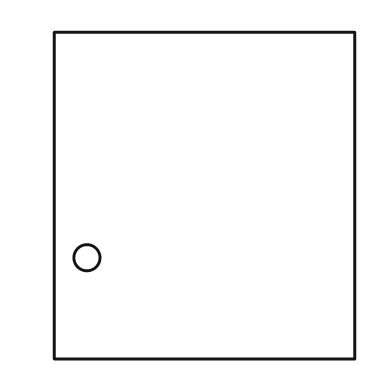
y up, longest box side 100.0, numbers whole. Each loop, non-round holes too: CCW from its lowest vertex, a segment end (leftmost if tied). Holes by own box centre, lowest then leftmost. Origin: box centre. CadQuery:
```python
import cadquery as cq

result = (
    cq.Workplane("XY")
    .moveTo(-46.0, -50.0)
    .lineTo(46.0, -50.0)
    .lineTo(46.0, 50.0)
    .lineTo(-46.0, 50.0)
    .close()
    .moveTo(-36.0, -19.0)
    .circle(4.0)
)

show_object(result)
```